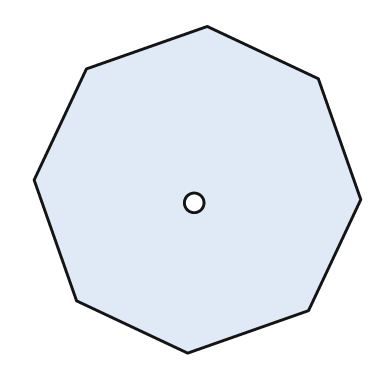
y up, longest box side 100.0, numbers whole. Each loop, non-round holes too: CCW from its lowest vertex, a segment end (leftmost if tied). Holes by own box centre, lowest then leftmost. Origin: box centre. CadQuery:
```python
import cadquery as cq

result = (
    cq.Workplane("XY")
    .moveTo(-3.0, -50.0)
    .lineTo(34.0, -37.0)
    .lineTo(50.0, -3.0)
    .lineTo(37.0, 34.0)
    .lineTo(3.0, 50.0)
    .lineTo(-34.0, 37.0)
    .lineTo(-50.0, 3.0)
    .lineTo(-37.0, -34.0)
    .close()
    .moveTo(-1.0, -4.0)
    .circle(3.0)
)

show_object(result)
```